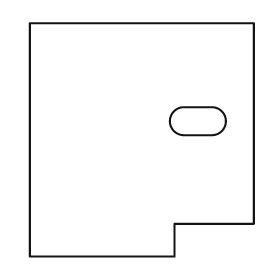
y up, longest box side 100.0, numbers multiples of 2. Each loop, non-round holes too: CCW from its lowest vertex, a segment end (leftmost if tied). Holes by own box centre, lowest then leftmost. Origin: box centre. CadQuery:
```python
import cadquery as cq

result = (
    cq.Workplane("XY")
    .moveTo(-48.0, -50.0)
    .lineTo(14.0, -50.0)
    .lineTo(14.0, -36.0)
    .lineTo(48.0, -36.0)
    .lineTo(48.0, 50.0)
    .lineTo(-48.0, 50.0)
    .close()
    .moveTo(18.0, 2.0)
    .lineTo(30.0, 2.0)
    .threePointArc((36.0, 8.0), (30.0, 14.0))
    .lineTo(18.0, 14.0)
    .threePointArc((12.0, 8.0), (18.0, 2.0))
    .close()
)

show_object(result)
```